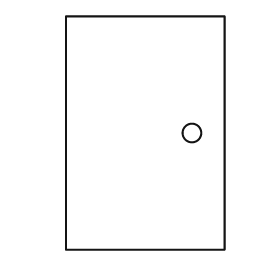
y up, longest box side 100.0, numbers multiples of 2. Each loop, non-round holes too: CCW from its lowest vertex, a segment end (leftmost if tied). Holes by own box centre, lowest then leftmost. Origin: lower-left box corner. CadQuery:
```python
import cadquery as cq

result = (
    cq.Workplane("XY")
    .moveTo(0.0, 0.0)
    .lineTo(68.0, 0.0)
    .lineTo(68.0, 100.0)
    .lineTo(0.0, 100.0)
    .close()
    .moveTo(54.0, 50.0)
    .circle(4.0)
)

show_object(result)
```